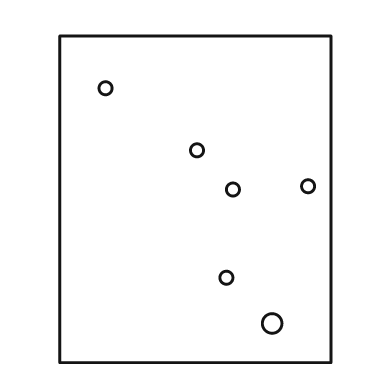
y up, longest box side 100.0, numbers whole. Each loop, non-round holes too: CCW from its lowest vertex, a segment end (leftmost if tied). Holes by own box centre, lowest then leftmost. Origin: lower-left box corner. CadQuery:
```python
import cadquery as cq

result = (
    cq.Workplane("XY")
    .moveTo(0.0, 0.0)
    .lineTo(83.0, 0.0)
    .lineTo(83.0, 100.0)
    .lineTo(0.0, 100.0)
    .close()
    .moveTo(65.0, 12.0)
    .circle(3.0)
    .moveTo(51.0, 26.0)
    .circle(2.0)
    .moveTo(53.0, 53.0)
    .circle(2.0)
    .moveTo(76.0, 54.0)
    .circle(2.0)
    .moveTo(42.0, 65.0)
    .circle(2.0)
    .moveTo(14.0, 84.0)
    .circle(2.0)
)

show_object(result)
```